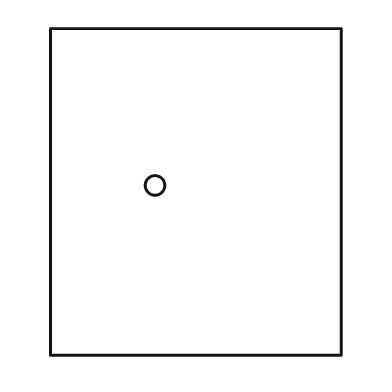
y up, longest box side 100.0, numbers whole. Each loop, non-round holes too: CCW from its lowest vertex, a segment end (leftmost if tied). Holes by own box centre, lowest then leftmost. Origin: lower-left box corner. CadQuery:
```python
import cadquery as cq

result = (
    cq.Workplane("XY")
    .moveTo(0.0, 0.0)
    .lineTo(89.0, 0.0)
    .lineTo(89.0, 100.0)
    .lineTo(0.0, 100.0)
    .close()
    .moveTo(32.0, 52.0)
    .circle(3.0)
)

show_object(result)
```